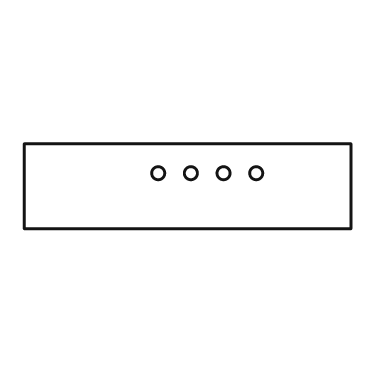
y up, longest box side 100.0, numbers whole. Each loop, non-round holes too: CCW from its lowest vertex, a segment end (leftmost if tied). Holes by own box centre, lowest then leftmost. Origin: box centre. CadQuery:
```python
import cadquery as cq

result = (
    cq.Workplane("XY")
    .moveTo(-50.0, -13.0)
    .lineTo(50.0, -13.0)
    .lineTo(50.0, 13.0)
    .lineTo(-50.0, 13.0)
    .close()
    .moveTo(-9.0, 4.0)
    .circle(2.0)
    .moveTo(1.0, 4.0)
    .circle(2.0)
    .moveTo(11.0, 4.0)
    .circle(2.0)
    .moveTo(21.0, 4.0)
    .circle(2.0)
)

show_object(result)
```